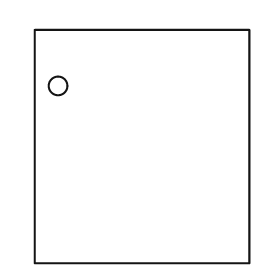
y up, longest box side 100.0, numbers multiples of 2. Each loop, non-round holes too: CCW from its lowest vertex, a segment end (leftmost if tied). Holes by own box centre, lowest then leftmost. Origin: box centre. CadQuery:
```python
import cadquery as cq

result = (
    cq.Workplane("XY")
    .moveTo(-46.0, -50.0)
    .lineTo(46.0, -50.0)
    .lineTo(46.0, 50.0)
    .lineTo(-46.0, 50.0)
    .close()
    .moveTo(-36.0, 26.0)
    .circle(4.0)
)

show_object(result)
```